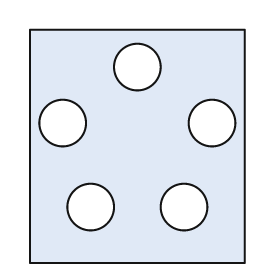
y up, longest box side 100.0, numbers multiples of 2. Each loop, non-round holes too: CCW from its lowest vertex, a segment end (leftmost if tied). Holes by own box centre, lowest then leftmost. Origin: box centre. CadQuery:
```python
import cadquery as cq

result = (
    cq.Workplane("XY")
    .moveTo(-46.0, -50.0)
    .lineTo(46.0, -50.0)
    .lineTo(46.0, 50.0)
    .lineTo(-46.0, 50.0)
    .close()
    .moveTo(-20.0, -26.0)
    .circle(10.0)
    .moveTo(20.0, -26.0)
    .circle(10.0)
    .moveTo(-32.0, 10.0)
    .circle(10.0)
    .moveTo(32.0, 10.0)
    .circle(10.0)
    .moveTo(0.0, 34.0)
    .circle(10.0)
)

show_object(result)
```